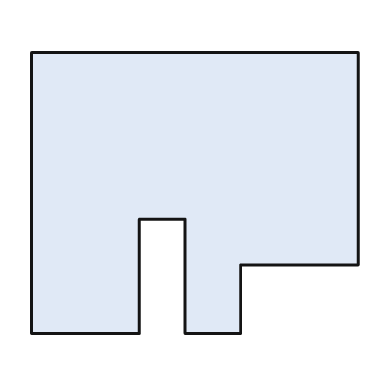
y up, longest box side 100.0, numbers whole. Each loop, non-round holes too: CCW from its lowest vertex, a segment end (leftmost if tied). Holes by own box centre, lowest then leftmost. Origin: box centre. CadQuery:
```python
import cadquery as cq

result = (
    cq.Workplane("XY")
    .moveTo(-50.0, -43.0)
    .lineTo(-17.0, -43.0)
    .lineTo(-17.0, -8.0)
    .lineTo(-3.0, -8.0)
    .lineTo(-3.0, -43.0)
    .lineTo(14.0, -43.0)
    .lineTo(14.0, -22.0)
    .lineTo(50.0, -22.0)
    .lineTo(50.0, 43.0)
    .lineTo(-50.0, 43.0)
    .close()
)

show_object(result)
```